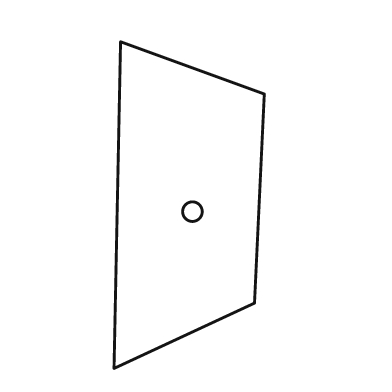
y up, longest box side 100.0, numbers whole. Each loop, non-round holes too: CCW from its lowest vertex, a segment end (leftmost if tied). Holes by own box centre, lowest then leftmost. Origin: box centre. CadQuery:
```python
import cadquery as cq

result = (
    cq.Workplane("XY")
    .moveTo(-23.0, -50.0)
    .lineTo(20.0, -30.0)
    .lineTo(23.0, 34.0)
    .lineTo(-21.0, 50.0)
    .close()
    .moveTo(1.0, -2.0)
    .circle(3.0)
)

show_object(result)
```